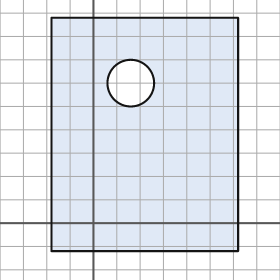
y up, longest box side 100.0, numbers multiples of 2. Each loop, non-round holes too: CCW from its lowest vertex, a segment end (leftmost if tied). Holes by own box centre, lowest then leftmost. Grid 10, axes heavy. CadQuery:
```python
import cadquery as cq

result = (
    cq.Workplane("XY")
    .moveTo(-18.0, -12.0)
    .lineTo(62.0, -12.0)
    .lineTo(62.0, 88.0)
    .lineTo(-18.0, 88.0)
    .close()
    .moveTo(16.0, 60.0)
    .circle(10.0)
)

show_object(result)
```